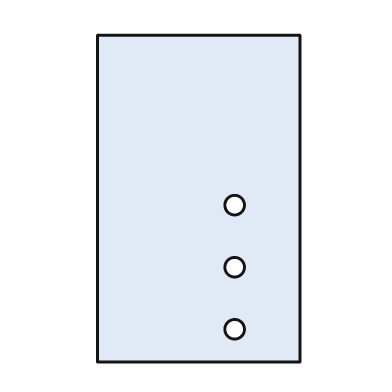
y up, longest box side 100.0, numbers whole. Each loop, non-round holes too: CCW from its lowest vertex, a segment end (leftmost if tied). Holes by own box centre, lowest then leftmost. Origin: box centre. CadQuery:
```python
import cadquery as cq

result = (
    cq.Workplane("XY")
    .moveTo(-31.0, -50.0)
    .lineTo(31.0, -50.0)
    .lineTo(31.0, 50.0)
    .lineTo(-31.0, 50.0)
    .close()
    .moveTo(11.0, -40.0)
    .circle(3.0)
    .moveTo(11.0, -21.0)
    .circle(3.0)
    .moveTo(11.0, -2.0)
    .circle(3.0)
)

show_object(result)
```